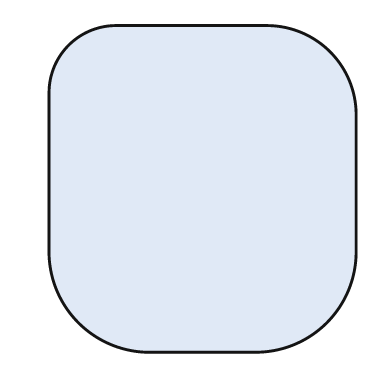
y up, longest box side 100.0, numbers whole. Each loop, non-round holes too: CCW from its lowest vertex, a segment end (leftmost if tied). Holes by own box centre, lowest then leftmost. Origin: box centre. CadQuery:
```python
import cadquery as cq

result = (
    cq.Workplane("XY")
    .moveTo(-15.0, -50.0)
    .lineTo(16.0, -50.0)
    .threePointArc((38.0, -41.0), (47.0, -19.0))
    .lineTo(47.0, 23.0)
    .threePointArc((39.0, 42.0), (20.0, 50.0))
    .lineTo(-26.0, 50.0)
    .threePointArc((-41.0, 44.0), (-47.0, 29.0))
    .lineTo(-47.0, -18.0)
    .threePointArc((-38.0, -41.0), (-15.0, -50.0))
    .close()
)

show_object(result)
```